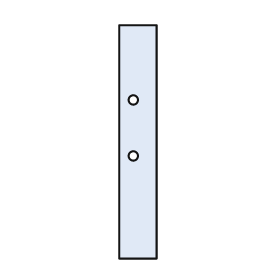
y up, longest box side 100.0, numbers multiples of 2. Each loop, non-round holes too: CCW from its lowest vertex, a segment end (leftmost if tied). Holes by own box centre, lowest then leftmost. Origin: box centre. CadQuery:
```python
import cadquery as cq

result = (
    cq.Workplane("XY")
    .moveTo(-8.0, -50.0)
    .lineTo(8.0, -50.0)
    .lineTo(8.0, 50.0)
    .lineTo(-8.0, 50.0)
    .close()
    .moveTo(-2.0, -6.0)
    .circle(2.0)
    .moveTo(-2.0, 18.0)
    .circle(2.0)
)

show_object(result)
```